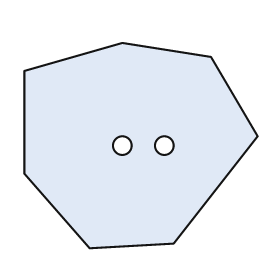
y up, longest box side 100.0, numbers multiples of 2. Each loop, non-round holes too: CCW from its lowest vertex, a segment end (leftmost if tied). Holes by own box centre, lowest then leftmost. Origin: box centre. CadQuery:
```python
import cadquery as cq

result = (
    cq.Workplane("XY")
    .moveTo(-22.0, -44.0)
    .lineTo(14.0, -42.0)
    .lineTo(50.0, 4.0)
    .lineTo(30.0, 38.0)
    .lineTo(-8.0, 44.0)
    .lineTo(-50.0, 32.0)
    .lineTo(-50.0, -12.0)
    .close()
    .moveTo(-8.0, 0.0)
    .circle(4.0)
    .moveTo(10.0, 0.0)
    .circle(4.0)
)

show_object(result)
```